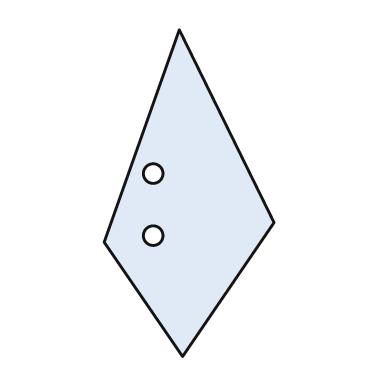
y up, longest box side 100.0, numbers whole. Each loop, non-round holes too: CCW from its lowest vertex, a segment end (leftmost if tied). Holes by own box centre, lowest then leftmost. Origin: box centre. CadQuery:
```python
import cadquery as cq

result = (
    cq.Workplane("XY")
    .moveTo(-2.0, -50.0)
    .lineTo(26.0, -9.0)
    .lineTo(-3.0, 50.0)
    .lineTo(-26.0, -15.0)
    .close()
    .moveTo(-11.0, -13.0)
    .circle(3.0)
    .moveTo(-11.0, 6.0)
    .circle(3.0)
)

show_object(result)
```